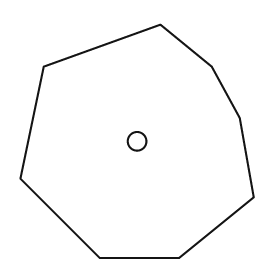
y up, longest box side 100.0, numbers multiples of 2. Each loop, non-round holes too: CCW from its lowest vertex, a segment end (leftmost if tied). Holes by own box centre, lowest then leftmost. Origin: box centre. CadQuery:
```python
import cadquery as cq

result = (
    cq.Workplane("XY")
    .moveTo(-16.0, -50.0)
    .lineTo(18.0, -50.0)
    .lineTo(50.0, -24.0)
    .lineTo(44.0, 10.0)
    .lineTo(32.0, 32.0)
    .lineTo(10.0, 50.0)
    .lineTo(-40.0, 32.0)
    .lineTo(-50.0, -16.0)
    .close()
    .moveTo(0.0, 0.0)
    .circle(4.0)
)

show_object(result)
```